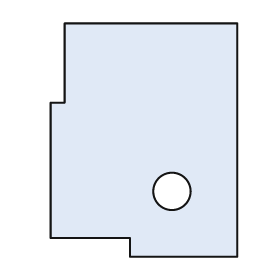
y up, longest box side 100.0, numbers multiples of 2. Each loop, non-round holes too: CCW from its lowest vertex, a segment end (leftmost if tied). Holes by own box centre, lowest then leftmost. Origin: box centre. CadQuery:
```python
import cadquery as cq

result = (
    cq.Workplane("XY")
    .moveTo(-6.0, -50.0)
    .lineTo(40.0, -50.0)
    .lineTo(40.0, 50.0)
    .lineTo(-34.0, 50.0)
    .lineTo(-34.0, 16.0)
    .lineTo(-40.0, 16.0)
    .lineTo(-40.0, -42.0)
    .lineTo(-6.0, -42.0)
    .close()
    .moveTo(12.0, -22.0)
    .circle(8.0)
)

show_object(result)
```